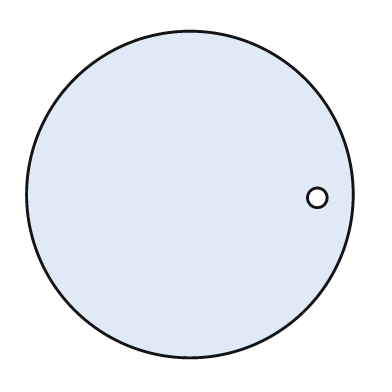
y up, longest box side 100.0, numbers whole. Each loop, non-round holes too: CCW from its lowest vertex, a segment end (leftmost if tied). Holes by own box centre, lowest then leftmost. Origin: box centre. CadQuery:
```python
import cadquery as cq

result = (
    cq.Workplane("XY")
    .moveTo(0.0, 0.0)
    .circle(50.0)
    .moveTo(39.0, -1.0)
    .circle(3.0)
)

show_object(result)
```